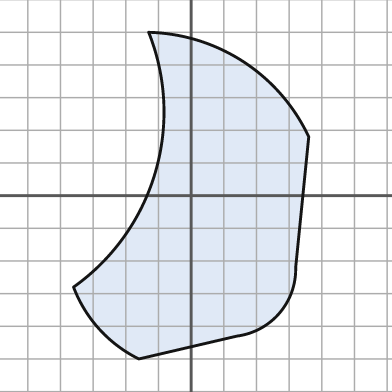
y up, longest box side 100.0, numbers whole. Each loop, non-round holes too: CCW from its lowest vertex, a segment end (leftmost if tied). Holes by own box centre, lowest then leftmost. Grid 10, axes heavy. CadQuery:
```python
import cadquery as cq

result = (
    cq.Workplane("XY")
    .moveTo(-16.0, -50.0)
    .lineTo(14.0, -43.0)
    .threePointArc((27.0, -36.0), (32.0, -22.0))
    .lineTo(36.0, 18.0)
    .threePointArc((16.0, 41.0), (-13.0, 50.0))
    .threePointArc((-11.0, 7.0), (-36.0, -28.0))
    .threePointArc((-28.0, -41.0), (-16.0, -50.0))
    .close()
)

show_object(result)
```